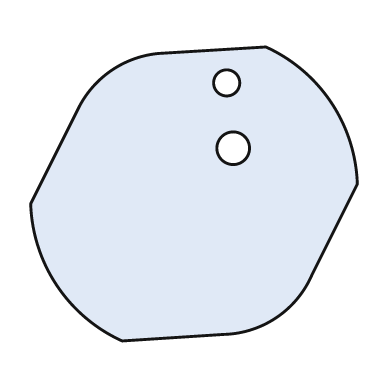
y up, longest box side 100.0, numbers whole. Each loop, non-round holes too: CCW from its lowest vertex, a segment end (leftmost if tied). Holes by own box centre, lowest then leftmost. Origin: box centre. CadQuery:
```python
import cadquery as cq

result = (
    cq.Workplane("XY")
    .moveTo(-22.0, -45.0)
    .lineTo(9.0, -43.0)
    .threePointArc((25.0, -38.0), (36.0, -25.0))
    .lineTo(50.0, 3.0)
    .threePointArc((42.0, 28.0), (22.0, 45.0))
    .lineTo(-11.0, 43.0)
    .threePointArc((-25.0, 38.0), (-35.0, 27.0))
    .lineTo(-50.0, -3.0)
    .threePointArc((-42.0, -28.0), (-22.0, -45.0))
    .close()
    .moveTo(12.0, 14.0)
    .circle(5.0)
    .moveTo(10.0, 34.0)
    .circle(4.0)
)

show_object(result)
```